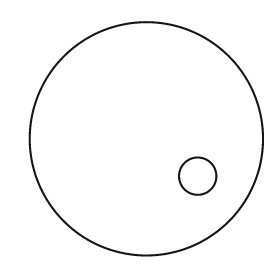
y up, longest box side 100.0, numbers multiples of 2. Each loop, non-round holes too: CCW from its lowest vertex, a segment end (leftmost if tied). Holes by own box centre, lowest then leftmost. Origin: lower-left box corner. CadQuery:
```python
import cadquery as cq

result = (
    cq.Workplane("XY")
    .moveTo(50.0, 50.0)
    .circle(50.0)
    .moveTo(72.0, 34.0)
    .circle(8.0)
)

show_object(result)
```